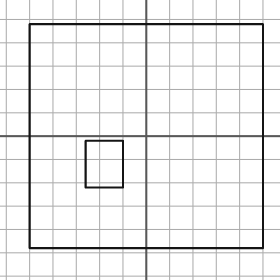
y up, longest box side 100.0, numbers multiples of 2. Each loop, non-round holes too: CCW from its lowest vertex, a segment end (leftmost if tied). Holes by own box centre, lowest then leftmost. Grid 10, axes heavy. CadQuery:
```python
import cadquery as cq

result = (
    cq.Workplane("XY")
    .moveTo(-50.0, -48.0)
    .lineTo(50.0, -48.0)
    .lineTo(50.0, 48.0)
    .lineTo(-50.0, 48.0)
    .close()
    .moveTo(-26.0, -22.0)
    .lineTo(-10.0, -22.0)
    .lineTo(-10.0, -2.0)
    .lineTo(-26.0, -2.0)
    .close()
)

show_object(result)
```